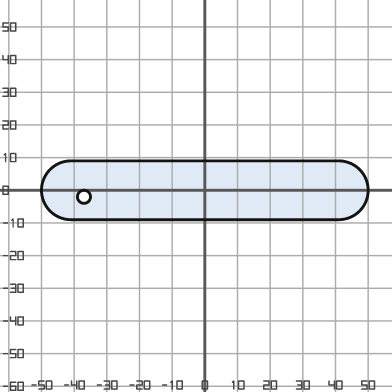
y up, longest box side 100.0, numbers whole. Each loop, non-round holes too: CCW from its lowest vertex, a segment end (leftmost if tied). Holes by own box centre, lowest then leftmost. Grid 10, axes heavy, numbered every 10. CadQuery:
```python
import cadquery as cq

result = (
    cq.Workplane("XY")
    .moveTo(-41.0, -9.0)
    .lineTo(41.0, -9.0)
    .threePointArc((50.0, 0.0), (41.0, 9.0))
    .lineTo(-41.0, 9.0)
    .threePointArc((-50.0, 0.0), (-41.0, -9.0))
    .close()
    .moveTo(-37.0, -2.0)
    .circle(2.0)
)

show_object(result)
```